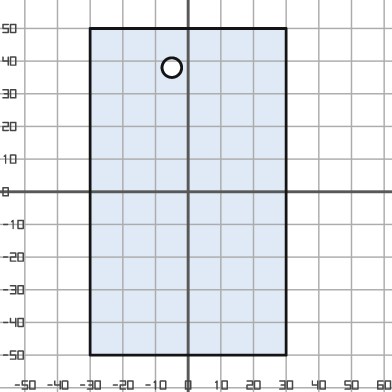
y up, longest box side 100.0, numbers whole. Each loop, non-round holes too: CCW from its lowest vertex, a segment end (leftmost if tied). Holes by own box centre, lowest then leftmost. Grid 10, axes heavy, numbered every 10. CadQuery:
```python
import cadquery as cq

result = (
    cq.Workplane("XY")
    .moveTo(-30.0, -50.0)
    .lineTo(30.0, -50.0)
    .lineTo(30.0, 50.0)
    .lineTo(-30.0, 50.0)
    .close()
    .moveTo(-5.0, 38.0)
    .circle(3.0)
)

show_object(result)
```